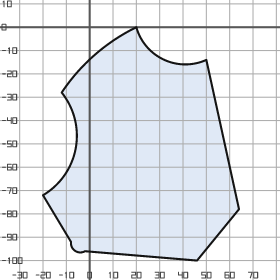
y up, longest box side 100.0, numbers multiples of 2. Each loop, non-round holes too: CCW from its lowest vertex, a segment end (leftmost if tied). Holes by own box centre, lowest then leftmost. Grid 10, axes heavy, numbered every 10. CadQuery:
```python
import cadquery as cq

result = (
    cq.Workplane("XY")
    .moveTo(46.0, -100.0)
    .lineTo(64.0, -78.0)
    .lineTo(50.0, -14.0)
    .threePointArc((32.0, -14.0), (20.0, 0.0))
    .threePointArc((2.0, -12.0), (-12.0, -28.0))
    .threePointArc((-6.0, -52.0), (-20.0, -72.0))
    .lineTo(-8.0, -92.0)
    .threePointArc((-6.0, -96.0), (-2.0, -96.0))
    .close()
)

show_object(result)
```